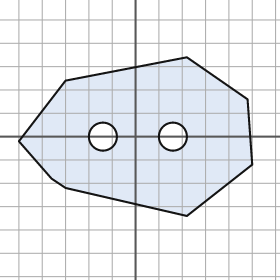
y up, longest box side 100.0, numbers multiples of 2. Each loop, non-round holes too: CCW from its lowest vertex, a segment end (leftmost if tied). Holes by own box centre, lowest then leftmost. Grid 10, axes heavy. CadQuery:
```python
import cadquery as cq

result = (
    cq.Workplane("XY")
    .moveTo(22.0, -34.0)
    .lineTo(50.0, -12.0)
    .lineTo(48.0, 16.0)
    .lineTo(22.0, 34.0)
    .lineTo(-30.0, 24.0)
    .lineTo(-50.0, -2.0)
    .lineTo(-36.0, -18.0)
    .lineTo(-30.0, -22.0)
    .close()
    .moveTo(-14.0, 0.0)
    .circle(6.0)
    .moveTo(16.0, 0.0)
    .circle(6.0)
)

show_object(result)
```